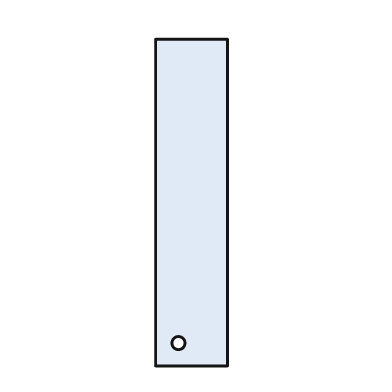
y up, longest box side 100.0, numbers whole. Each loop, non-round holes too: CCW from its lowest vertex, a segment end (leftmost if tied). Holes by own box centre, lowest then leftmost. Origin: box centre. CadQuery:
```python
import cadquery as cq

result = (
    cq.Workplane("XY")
    .moveTo(-11.0, -50.0)
    .lineTo(11.0, -50.0)
    .lineTo(11.0, 50.0)
    .lineTo(-11.0, 50.0)
    .close()
    .moveTo(-4.0, -43.0)
    .circle(2.0)
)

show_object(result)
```